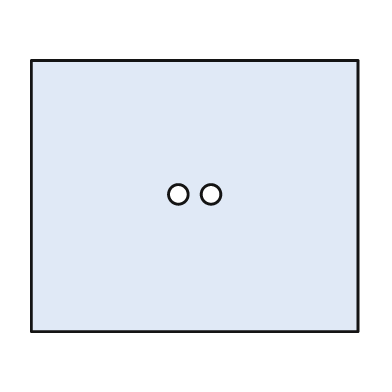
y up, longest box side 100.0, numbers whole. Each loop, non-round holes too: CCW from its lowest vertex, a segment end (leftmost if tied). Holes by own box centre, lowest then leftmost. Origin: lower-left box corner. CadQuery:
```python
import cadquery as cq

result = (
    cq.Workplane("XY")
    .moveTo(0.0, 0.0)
    .lineTo(100.0, 0.0)
    .lineTo(100.0, 83.0)
    .lineTo(0.0, 83.0)
    .close()
    .moveTo(45.0, 42.0)
    .circle(3.0)
    .moveTo(55.0, 42.0)
    .circle(3.0)
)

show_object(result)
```